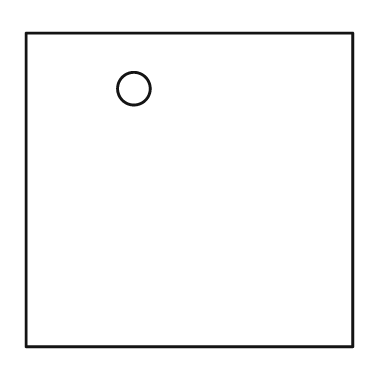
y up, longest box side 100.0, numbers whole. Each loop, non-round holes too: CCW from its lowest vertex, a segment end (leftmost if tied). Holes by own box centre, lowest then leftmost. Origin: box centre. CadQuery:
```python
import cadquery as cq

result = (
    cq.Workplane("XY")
    .moveTo(-50.0, -48.0)
    .lineTo(50.0, -48.0)
    .lineTo(50.0, 48.0)
    .lineTo(-50.0, 48.0)
    .close()
    .moveTo(-17.0, 31.0)
    .circle(5.0)
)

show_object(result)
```